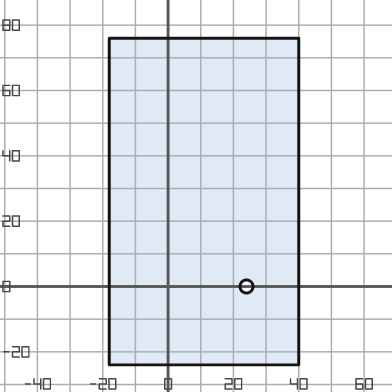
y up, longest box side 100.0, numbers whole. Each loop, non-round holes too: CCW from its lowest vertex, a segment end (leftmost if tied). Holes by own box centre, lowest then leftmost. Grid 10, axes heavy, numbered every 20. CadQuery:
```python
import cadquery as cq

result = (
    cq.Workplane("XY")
    .moveTo(-18.0, -24.0)
    .lineTo(40.0, -24.0)
    .lineTo(40.0, 76.0)
    .lineTo(-18.0, 76.0)
    .close()
    .moveTo(24.0, 0.0)
    .circle(2.0)
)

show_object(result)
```